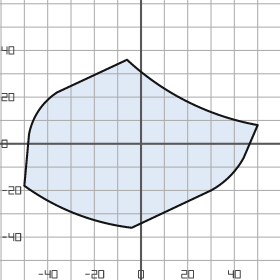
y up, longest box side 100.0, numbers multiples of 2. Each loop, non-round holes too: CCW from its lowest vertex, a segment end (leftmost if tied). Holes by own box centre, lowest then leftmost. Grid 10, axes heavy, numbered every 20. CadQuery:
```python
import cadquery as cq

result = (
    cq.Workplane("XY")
    .moveTo(-4.0, -36.0)
    .lineTo(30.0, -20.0)
    .threePointArc((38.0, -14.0), (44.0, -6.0))
    .lineTo(50.0, 8.0)
    .threePointArc((20.0, 18.0), (-6.0, 36.0))
    .lineTo(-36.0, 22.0)
    .threePointArc((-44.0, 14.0), (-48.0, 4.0))
    .lineTo(-50.0, -18.0)
    .threePointArc((-28.0, -30.0), (-4.0, -36.0))
    .close()
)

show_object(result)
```